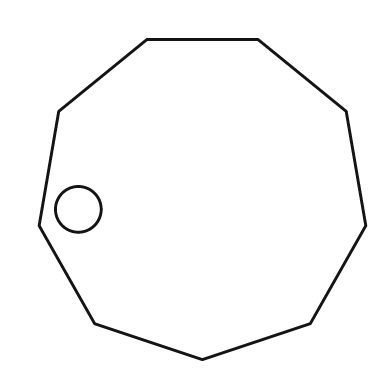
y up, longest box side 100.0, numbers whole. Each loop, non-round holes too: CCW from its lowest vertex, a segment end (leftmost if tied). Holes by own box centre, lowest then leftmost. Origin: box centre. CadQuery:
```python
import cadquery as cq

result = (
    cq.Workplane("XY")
    .moveTo(0.0, -49.0)
    .lineTo(33.0, -38.0)
    .lineTo(50.0, -8.0)
    .lineTo(44.0, 27.0)
    .lineTo(17.0, 49.0)
    .lineTo(-17.0, 49.0)
    .lineTo(-44.0, 27.0)
    .lineTo(-50.0, -8.0)
    .lineTo(-33.0, -38.0)
    .close()
    .moveTo(-38.0, -3.0)
    .circle(7.0)
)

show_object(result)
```